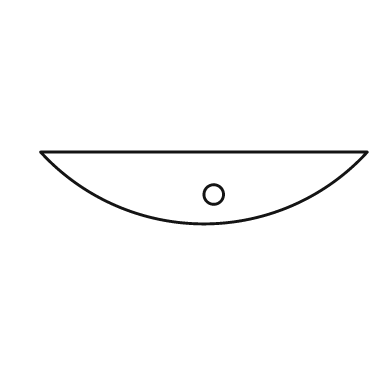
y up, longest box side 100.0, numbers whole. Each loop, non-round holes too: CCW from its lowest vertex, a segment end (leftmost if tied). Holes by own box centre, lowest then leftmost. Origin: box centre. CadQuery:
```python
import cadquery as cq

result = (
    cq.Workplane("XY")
    .moveTo(-50.0, 11.0)
    .threePointArc((0.0, -11.0), (50.0, 11.0))
    .close()
    .moveTo(3.0, -2.0)
    .circle(3.0)
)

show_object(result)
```